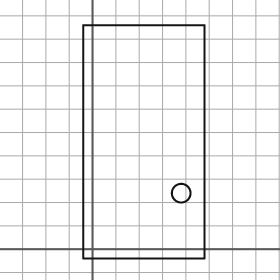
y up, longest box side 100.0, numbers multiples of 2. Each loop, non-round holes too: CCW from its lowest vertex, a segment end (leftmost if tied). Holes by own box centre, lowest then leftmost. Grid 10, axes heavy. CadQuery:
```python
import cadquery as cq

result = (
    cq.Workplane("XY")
    .moveTo(-4.0, -4.0)
    .lineTo(48.0, -4.0)
    .lineTo(48.0, 96.0)
    .lineTo(-4.0, 96.0)
    .close()
    .moveTo(38.0, 24.0)
    .circle(4.0)
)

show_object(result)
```